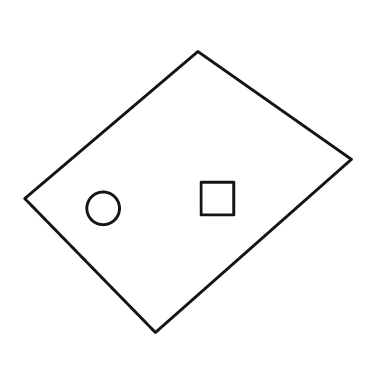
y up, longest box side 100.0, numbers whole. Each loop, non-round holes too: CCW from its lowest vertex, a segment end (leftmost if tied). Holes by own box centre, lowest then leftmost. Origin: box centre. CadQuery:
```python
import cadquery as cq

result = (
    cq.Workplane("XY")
    .moveTo(-10.0, -43.0)
    .lineTo(50.0, 10.0)
    .lineTo(3.0, 43.0)
    .lineTo(-50.0, -2.0)
    .close()
    .moveTo(-26.0, -5.0)
    .circle(5.0)
    .moveTo(4.0, -7.0)
    .lineTo(14.0, -7.0)
    .lineTo(14.0, 3.0)
    .lineTo(4.0, 3.0)
    .close()
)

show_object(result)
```